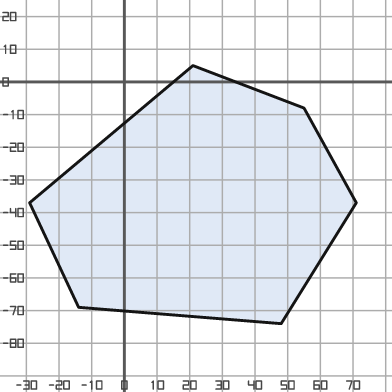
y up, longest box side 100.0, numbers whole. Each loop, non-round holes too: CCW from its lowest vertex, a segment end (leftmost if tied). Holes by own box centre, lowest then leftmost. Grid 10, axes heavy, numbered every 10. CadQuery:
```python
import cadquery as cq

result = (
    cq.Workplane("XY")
    .moveTo(48.0, -74.0)
    .lineTo(71.0, -37.0)
    .lineTo(55.0, -8.0)
    .lineTo(21.0, 5.0)
    .lineTo(-29.0, -37.0)
    .lineTo(-14.0, -69.0)
    .close()
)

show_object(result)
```